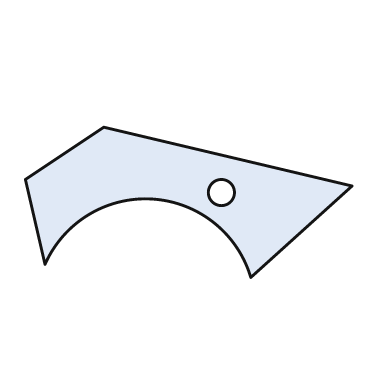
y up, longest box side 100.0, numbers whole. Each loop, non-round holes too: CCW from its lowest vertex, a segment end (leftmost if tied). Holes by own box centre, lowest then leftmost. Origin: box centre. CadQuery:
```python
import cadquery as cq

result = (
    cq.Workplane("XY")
    .moveTo(19.0, -23.0)
    .lineTo(50.0, 5.0)
    .lineTo(-26.0, 23.0)
    .lineTo(-50.0, 7.0)
    .lineTo(-44.0, -19.0)
    .threePointArc((-11.0, 1.0), (19.0, -23.0))
    .close()
    .moveTo(10.0, 3.0)
    .circle(4.0)
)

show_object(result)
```